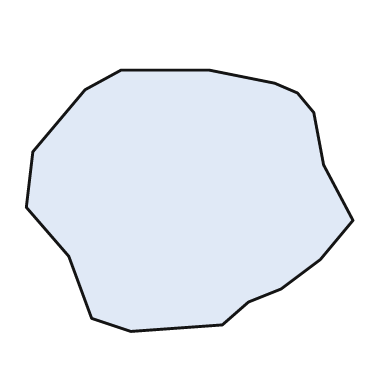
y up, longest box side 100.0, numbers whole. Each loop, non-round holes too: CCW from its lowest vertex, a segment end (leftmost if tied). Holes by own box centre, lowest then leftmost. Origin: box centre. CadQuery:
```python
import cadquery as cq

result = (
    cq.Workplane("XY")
    .moveTo(-18.0, -40.0)
    .lineTo(10.0, -38.0)
    .lineTo(18.0, -31.0)
    .lineTo(28.0, -27.0)
    .lineTo(40.0, -18.0)
    .lineTo(50.0, -6.0)
    .lineTo(41.0, 11.0)
    .lineTo(38.0, 27.0)
    .lineTo(33.0, 33.0)
    .lineTo(26.0, 36.0)
    .lineTo(6.0, 40.0)
    .lineTo(-21.0, 40.0)
    .lineTo(-32.0, 34.0)
    .lineTo(-48.0, 15.0)
    .lineTo(-50.0, -2.0)
    .lineTo(-37.0, -17.0)
    .lineTo(-30.0, -36.0)
    .close()
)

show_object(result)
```